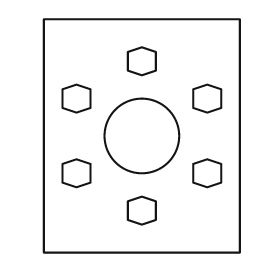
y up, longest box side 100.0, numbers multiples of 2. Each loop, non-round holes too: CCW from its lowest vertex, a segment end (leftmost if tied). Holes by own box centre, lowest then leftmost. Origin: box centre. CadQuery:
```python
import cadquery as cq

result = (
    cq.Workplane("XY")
    .moveTo(-42.0, -50.0)
    .lineTo(42.0, -50.0)
    .lineTo(42.0, 50.0)
    .lineTo(-42.0, 50.0)
    .close()
    .moveTo(0.0, -38.0)
    .lineTo(6.0, -36.0)
    .lineTo(6.0, -28.0)
    .lineTo(0.0, -26.0)
    .lineTo(-6.0, -28.0)
    .lineTo(-6.0, -36.0)
    .close()
    .moveTo(-28.0, -22.0)
    .lineTo(-22.0, -20.0)
    .lineTo(-22.0, -12.0)
    .lineTo(-28.0, -10.0)
    .lineTo(-34.0, -12.0)
    .lineTo(-34.0, -20.0)
    .close()
    .moveTo(28.0, -22.0)
    .lineTo(34.0, -20.0)
    .lineTo(34.0, -12.0)
    .lineTo(28.0, -10.0)
    .lineTo(22.0, -12.0)
    .lineTo(22.0, -20.0)
    .close()
    .moveTo(0.0, 0.0)
    .circle(16.0)
    .moveTo(-28.0, 10.0)
    .lineTo(-22.0, 12.0)
    .lineTo(-22.0, 20.0)
    .lineTo(-28.0, 22.0)
    .lineTo(-34.0, 20.0)
    .lineTo(-34.0, 12.0)
    .close()
    .moveTo(28.0, 10.0)
    .lineTo(34.0, 12.0)
    .lineTo(34.0, 20.0)
    .lineTo(28.0, 22.0)
    .lineTo(22.0, 20.0)
    .lineTo(22.0, 12.0)
    .close()
    .moveTo(0.0, 26.0)
    .lineTo(6.0, 28.0)
    .lineTo(6.0, 36.0)
    .lineTo(0.0, 38.0)
    .lineTo(-6.0, 36.0)
    .lineTo(-6.0, 28.0)
    .close()
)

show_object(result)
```